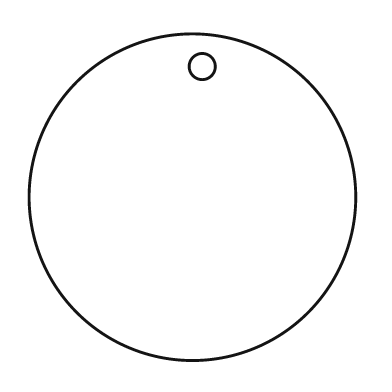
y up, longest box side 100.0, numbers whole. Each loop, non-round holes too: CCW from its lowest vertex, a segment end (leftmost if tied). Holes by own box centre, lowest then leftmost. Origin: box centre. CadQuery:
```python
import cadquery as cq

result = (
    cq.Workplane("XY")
    .moveTo(0.0, 0.0)
    .circle(50.0)
    .moveTo(3.0, 40.0)
    .circle(4.0)
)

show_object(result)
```